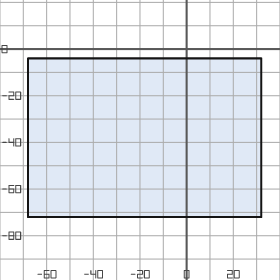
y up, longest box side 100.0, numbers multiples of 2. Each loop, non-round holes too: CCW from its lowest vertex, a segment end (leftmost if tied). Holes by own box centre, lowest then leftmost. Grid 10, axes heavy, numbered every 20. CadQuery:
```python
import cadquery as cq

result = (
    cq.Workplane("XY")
    .moveTo(-68.0, -72.0)
    .lineTo(32.0, -72.0)
    .lineTo(32.0, -4.0)
    .lineTo(-68.0, -4.0)
    .close()
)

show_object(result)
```